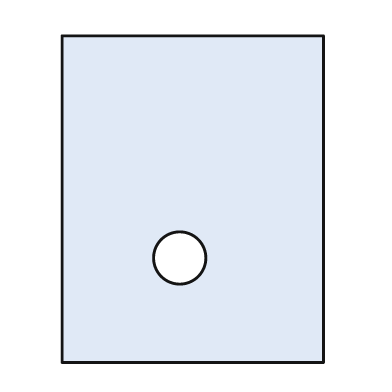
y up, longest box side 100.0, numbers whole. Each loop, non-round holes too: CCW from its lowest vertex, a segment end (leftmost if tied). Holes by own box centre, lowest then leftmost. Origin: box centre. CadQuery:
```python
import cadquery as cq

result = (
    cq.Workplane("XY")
    .moveTo(-40.0, -50.0)
    .lineTo(40.0, -50.0)
    .lineTo(40.0, 50.0)
    .lineTo(-40.0, 50.0)
    .close()
    .moveTo(-4.0, -18.0)
    .circle(8.0)
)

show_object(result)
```